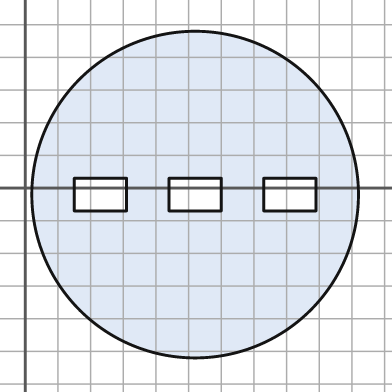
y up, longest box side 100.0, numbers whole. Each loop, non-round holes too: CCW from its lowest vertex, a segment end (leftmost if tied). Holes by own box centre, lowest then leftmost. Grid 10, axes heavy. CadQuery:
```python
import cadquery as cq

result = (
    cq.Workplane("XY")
    .moveTo(52.0, -2.0)
    .circle(50.0)
    .moveTo(15.0, -7.0)
    .lineTo(31.0, -7.0)
    .lineTo(31.0, 3.0)
    .lineTo(15.0, 3.0)
    .close()
    .moveTo(44.0, -7.0)
    .lineTo(60.0, -7.0)
    .lineTo(60.0, 3.0)
    .lineTo(44.0, 3.0)
    .close()
    .moveTo(73.0, -7.0)
    .lineTo(89.0, -7.0)
    .lineTo(89.0, 3.0)
    .lineTo(73.0, 3.0)
    .close()
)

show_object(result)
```